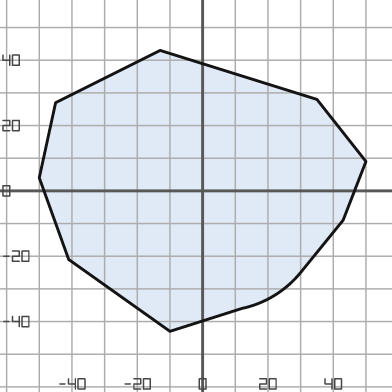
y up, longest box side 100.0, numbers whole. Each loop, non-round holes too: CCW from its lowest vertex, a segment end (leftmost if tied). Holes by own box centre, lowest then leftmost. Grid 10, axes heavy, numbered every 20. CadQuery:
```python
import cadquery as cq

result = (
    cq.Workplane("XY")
    .moveTo(-10.0, -43.0)
    .lineTo(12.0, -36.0)
    .threePointArc((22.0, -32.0), (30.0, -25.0))
    .lineTo(43.0, -9.0)
    .lineTo(50.0, 9.0)
    .lineTo(35.0, 28.0)
    .lineTo(-13.0, 43.0)
    .lineTo(-45.0, 27.0)
    .lineTo(-50.0, 4.0)
    .lineTo(-41.0, -21.0)
    .close()
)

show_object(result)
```